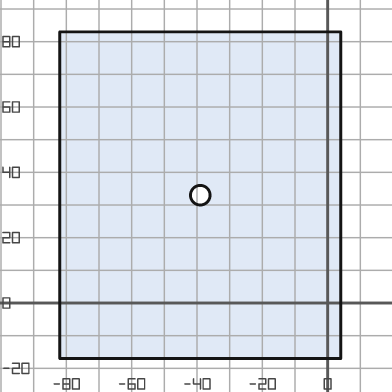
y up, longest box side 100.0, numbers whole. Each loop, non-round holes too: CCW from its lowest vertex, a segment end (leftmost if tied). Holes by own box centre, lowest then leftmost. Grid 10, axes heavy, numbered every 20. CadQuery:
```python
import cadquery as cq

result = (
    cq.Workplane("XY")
    .moveTo(-82.0, -17.0)
    .lineTo(4.0, -17.0)
    .lineTo(4.0, 83.0)
    .lineTo(-82.0, 83.0)
    .close()
    .moveTo(-39.0, 33.0)
    .circle(3.0)
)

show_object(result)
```